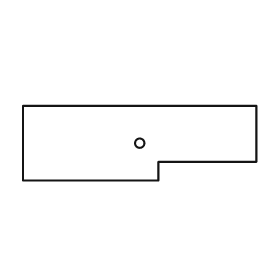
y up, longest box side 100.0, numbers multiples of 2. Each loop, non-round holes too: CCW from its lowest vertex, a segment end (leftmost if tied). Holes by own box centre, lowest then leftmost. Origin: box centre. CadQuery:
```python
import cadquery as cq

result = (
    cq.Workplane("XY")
    .moveTo(-50.0, -16.0)
    .lineTo(8.0, -16.0)
    .lineTo(8.0, -8.0)
    .lineTo(50.0, -8.0)
    .lineTo(50.0, 16.0)
    .lineTo(-50.0, 16.0)
    .close()
    .moveTo(0.0, 0.0)
    .circle(2.0)
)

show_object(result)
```